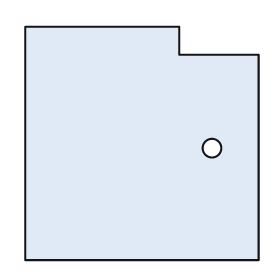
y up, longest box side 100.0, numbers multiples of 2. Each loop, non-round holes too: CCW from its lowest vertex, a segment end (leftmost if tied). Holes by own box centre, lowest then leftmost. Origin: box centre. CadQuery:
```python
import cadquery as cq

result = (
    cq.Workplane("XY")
    .moveTo(-50.0, -50.0)
    .lineTo(50.0, -50.0)
    .lineTo(50.0, 38.0)
    .lineTo(16.0, 38.0)
    .lineTo(16.0, 50.0)
    .lineTo(-50.0, 50.0)
    .close()
    .moveTo(30.0, -2.0)
    .circle(4.0)
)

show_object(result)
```